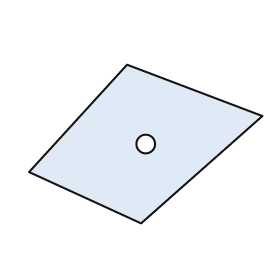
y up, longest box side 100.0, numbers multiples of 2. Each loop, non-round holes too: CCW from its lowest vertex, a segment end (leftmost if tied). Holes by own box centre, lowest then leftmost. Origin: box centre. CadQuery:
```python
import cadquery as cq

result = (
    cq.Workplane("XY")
    .moveTo(-2.0, -34.0)
    .lineTo(50.0, 12.0)
    .lineTo(-8.0, 34.0)
    .lineTo(-50.0, -12.0)
    .close()
    .moveTo(0.0, 0.0)
    .circle(4.0)
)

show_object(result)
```